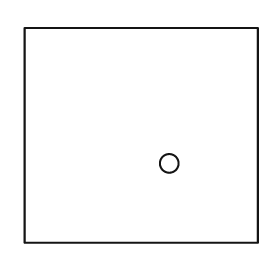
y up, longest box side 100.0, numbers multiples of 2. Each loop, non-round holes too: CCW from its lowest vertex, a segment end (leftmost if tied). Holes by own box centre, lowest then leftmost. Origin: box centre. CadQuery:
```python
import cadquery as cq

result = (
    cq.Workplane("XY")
    .moveTo(-50.0, -46.0)
    .lineTo(50.0, -46.0)
    .lineTo(50.0, 46.0)
    .lineTo(-50.0, 46.0)
    .close()
    .moveTo(12.0, -12.0)
    .circle(4.0)
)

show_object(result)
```